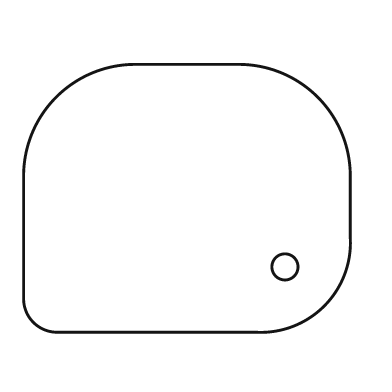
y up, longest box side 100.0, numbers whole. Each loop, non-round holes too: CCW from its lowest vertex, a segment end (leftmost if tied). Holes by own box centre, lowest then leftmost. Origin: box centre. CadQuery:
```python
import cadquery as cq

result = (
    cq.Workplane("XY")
    .moveTo(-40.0, -41.0)
    .lineTo(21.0, -41.0)
    .threePointArc((42.0, -33.0), (50.0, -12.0))
    .lineTo(50.0, 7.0)
    .threePointArc((40.0, 31.0), (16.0, 41.0))
    .lineTo(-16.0, 41.0)
    .threePointArc((-40.0, 31.0), (-50.0, 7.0))
    .lineTo(-50.0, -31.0)
    .threePointArc((-47.0, -38.0), (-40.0, -41.0))
    .close()
    .moveTo(30.0, -21.0)
    .circle(4.0)
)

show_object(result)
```